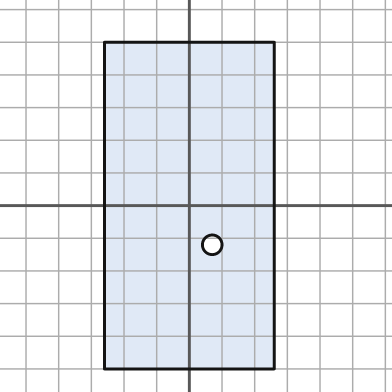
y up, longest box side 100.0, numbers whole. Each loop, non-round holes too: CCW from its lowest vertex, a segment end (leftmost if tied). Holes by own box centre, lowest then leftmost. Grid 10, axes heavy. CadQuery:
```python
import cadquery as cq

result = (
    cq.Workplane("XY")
    .moveTo(-26.0, -50.0)
    .lineTo(26.0, -50.0)
    .lineTo(26.0, 50.0)
    .lineTo(-26.0, 50.0)
    .close()
    .moveTo(7.0, -12.0)
    .circle(3.0)
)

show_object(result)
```